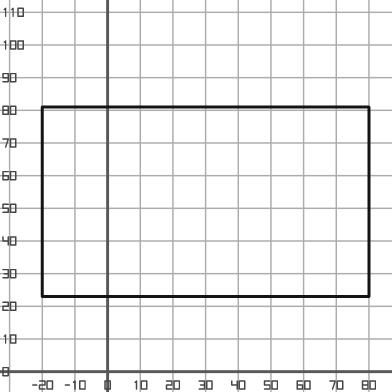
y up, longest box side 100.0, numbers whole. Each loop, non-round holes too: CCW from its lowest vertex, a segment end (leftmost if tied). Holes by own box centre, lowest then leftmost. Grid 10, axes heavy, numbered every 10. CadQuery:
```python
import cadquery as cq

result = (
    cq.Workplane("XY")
    .moveTo(-20.0, 23.0)
    .lineTo(80.0, 23.0)
    .lineTo(80.0, 81.0)
    .lineTo(-20.0, 81.0)
    .close()
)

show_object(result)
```